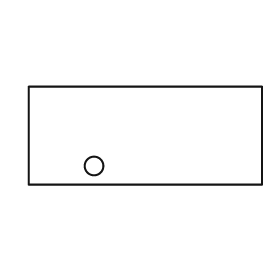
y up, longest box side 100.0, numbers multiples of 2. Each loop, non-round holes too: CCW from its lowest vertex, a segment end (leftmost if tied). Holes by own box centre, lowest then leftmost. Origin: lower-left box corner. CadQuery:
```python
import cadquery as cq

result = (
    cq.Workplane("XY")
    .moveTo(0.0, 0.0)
    .lineTo(100.0, 0.0)
    .lineTo(100.0, 42.0)
    .lineTo(0.0, 42.0)
    .close()
    .moveTo(28.0, 8.0)
    .circle(4.0)
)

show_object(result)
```